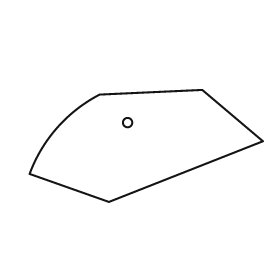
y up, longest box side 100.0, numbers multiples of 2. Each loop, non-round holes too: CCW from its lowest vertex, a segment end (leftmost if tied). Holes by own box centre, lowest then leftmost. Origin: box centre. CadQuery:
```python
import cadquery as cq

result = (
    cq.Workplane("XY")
    .moveTo(-16.0, -24.0)
    .lineTo(50.0, 2.0)
    .lineTo(24.0, 24.0)
    .lineTo(-20.0, 22.0)
    .threePointArc((-38.0, 8.0), (-50.0, -12.0))
    .close()
    .moveTo(-8.0, 10.0)
    .circle(2.0)
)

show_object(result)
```